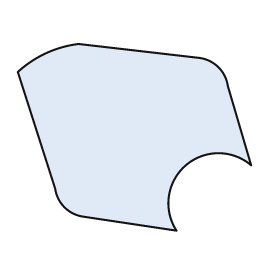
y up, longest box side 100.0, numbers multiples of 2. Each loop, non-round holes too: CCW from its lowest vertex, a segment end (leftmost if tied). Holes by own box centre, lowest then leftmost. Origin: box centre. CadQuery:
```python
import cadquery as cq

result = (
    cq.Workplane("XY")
    .moveTo(18.0, -40.0)
    .threePointArc((22.0, -12.0), (50.0, -12.0))
    .lineTo(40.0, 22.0)
    .threePointArc((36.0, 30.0), (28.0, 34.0))
    .lineTo(-24.0, 40.0)
    .threePointArc((-38.0, 36.0), (-50.0, 28.0))
    .lineTo(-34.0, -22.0)
    .threePointArc((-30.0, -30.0), (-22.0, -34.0))
    .close()
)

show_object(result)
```